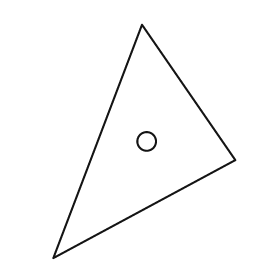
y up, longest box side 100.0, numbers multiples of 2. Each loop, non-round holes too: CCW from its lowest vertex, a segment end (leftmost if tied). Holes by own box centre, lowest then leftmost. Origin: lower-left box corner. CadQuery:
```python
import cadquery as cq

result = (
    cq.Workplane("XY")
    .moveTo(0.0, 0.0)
    .lineTo(78.0, 42.0)
    .lineTo(38.0, 100.0)
    .close()
    .moveTo(40.0, 50.0)
    .circle(4.0)
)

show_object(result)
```